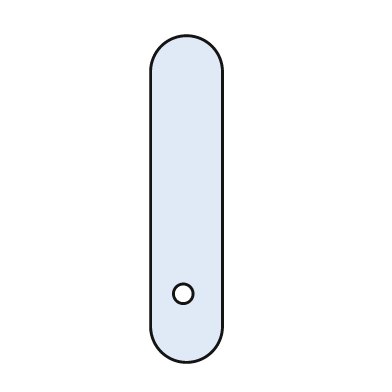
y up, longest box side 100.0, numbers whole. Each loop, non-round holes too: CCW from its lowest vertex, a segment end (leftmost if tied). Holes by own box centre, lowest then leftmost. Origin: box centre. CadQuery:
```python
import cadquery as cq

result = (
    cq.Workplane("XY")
    .moveTo(-11.0, -39.0)
    .threePointArc((0.0, -50.0), (11.0, -39.0))
    .lineTo(11.0, 39.0)
    .threePointArc((0.0, 50.0), (-11.0, 39.0))
    .close()
    .moveTo(-1.0, -29.0)
    .circle(3.0)
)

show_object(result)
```